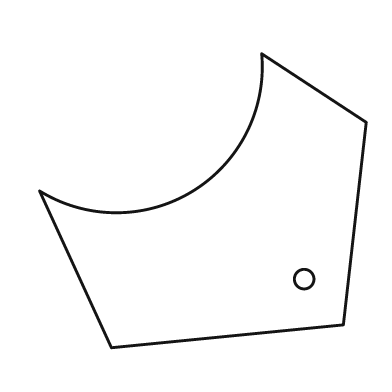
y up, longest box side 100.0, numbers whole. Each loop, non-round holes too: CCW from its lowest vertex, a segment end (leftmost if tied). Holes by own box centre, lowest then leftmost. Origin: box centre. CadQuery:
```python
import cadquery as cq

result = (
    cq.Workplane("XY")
    .moveTo(-28.0, -45.0)
    .lineTo(43.0, -38.0)
    .lineTo(50.0, 24.0)
    .lineTo(18.0, 45.0)
    .threePointArc((-3.0, 3.0), (-50.0, 3.0))
    .close()
    .moveTo(31.0, -24.0)
    .circle(3.0)
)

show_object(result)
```